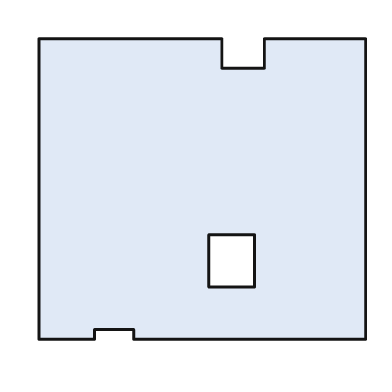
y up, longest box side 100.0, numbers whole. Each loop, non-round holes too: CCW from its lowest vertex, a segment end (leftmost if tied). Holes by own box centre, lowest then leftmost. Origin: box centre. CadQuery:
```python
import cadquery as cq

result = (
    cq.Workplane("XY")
    .moveTo(-50.0, -46.0)
    .lineTo(-33.0, -46.0)
    .lineTo(-33.0, -43.0)
    .lineTo(-21.0, -43.0)
    .lineTo(-21.0, -46.0)
    .lineTo(50.0, -46.0)
    .lineTo(50.0, 46.0)
    .lineTo(19.0, 46.0)
    .lineTo(19.0, 37.0)
    .lineTo(6.0, 37.0)
    .lineTo(6.0, 46.0)
    .lineTo(-50.0, 46.0)
    .close()
    .moveTo(2.0, -30.0)
    .lineTo(16.0, -30.0)
    .lineTo(16.0, -14.0)
    .lineTo(2.0, -14.0)
    .close()
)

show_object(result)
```